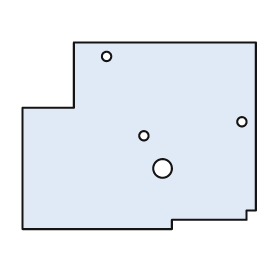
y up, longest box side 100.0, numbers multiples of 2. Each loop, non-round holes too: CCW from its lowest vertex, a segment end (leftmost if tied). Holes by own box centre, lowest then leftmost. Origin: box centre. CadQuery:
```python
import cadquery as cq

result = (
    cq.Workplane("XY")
    .moveTo(-50.0, -40.0)
    .lineTo(14.0, -40.0)
    .lineTo(14.0, -36.0)
    .lineTo(46.0, -36.0)
    .lineTo(46.0, -32.0)
    .lineTo(50.0, -32.0)
    .lineTo(50.0, 40.0)
    .lineTo(-28.0, 40.0)
    .lineTo(-28.0, 12.0)
    .lineTo(-50.0, 12.0)
    .close()
    .moveTo(10.0, -14.0)
    .circle(4.0)
    .moveTo(2.0, 0.0)
    .circle(2.0)
    .moveTo(44.0, 6.0)
    .circle(2.0)
    .moveTo(-14.0, 34.0)
    .circle(2.0)
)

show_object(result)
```